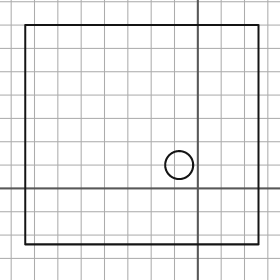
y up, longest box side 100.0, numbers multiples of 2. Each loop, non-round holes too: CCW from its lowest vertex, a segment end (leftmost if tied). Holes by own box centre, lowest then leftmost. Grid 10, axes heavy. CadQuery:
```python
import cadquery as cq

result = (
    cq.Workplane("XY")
    .moveTo(-74.0, -24.0)
    .lineTo(26.0, -24.0)
    .lineTo(26.0, 70.0)
    .lineTo(-74.0, 70.0)
    .close()
    .moveTo(-8.0, 10.0)
    .circle(6.0)
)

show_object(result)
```